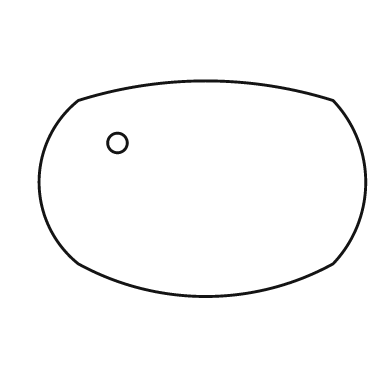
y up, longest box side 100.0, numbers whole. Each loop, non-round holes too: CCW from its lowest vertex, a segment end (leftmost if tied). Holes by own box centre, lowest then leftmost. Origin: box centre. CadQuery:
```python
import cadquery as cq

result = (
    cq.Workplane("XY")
    .moveTo(-38.0, -23.0)
    .threePointArc((1.0, -33.0), (40.0, -23.0))
    .threePointArc((50.0, 2.0), (40.0, 27.0))
    .threePointArc((1.0, 33.0), (-38.0, 27.0))
    .threePointArc((-50.0, 2.0), (-38.0, -23.0))
    .close()
    .moveTo(-26.0, 14.0)
    .circle(3.0)
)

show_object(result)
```